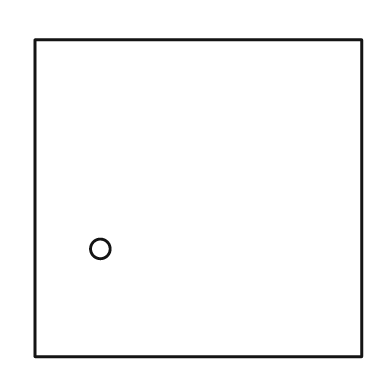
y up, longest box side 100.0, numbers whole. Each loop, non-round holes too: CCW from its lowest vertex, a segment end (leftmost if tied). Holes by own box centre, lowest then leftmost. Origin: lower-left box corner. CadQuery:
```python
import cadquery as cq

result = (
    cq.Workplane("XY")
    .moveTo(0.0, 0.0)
    .lineTo(100.0, 0.0)
    .lineTo(100.0, 97.0)
    .lineTo(0.0, 97.0)
    .close()
    .moveTo(20.0, 33.0)
    .circle(3.0)
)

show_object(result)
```